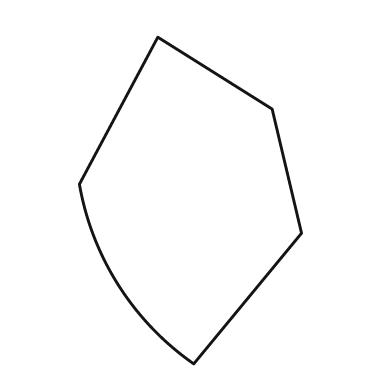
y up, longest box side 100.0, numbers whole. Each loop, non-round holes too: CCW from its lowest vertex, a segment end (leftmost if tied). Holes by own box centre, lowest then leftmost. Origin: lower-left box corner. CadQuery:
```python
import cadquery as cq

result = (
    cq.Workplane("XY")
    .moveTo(35.0, 0.0)
    .lineTo(68.0, 40.0)
    .lineTo(59.0, 78.0)
    .lineTo(24.0, 100.0)
    .lineTo(0.0, 55.0)
    .threePointArc((12.0, 24.0), (35.0, 0.0))
    .close()
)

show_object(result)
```